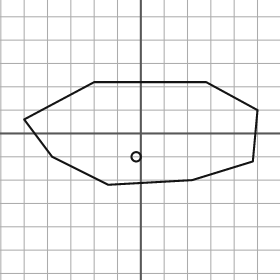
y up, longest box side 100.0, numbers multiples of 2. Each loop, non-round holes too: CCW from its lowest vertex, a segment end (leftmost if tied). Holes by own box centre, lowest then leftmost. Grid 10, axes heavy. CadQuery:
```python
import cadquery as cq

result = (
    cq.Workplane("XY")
    .moveTo(-14.0, -22.0)
    .lineTo(22.0, -20.0)
    .lineTo(48.0, -12.0)
    .lineTo(50.0, 10.0)
    .lineTo(28.0, 22.0)
    .lineTo(-20.0, 22.0)
    .lineTo(-50.0, 6.0)
    .lineTo(-38.0, -10.0)
    .close()
    .moveTo(-2.0, -10.0)
    .circle(2.0)
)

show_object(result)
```